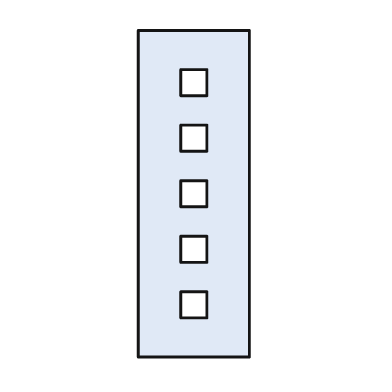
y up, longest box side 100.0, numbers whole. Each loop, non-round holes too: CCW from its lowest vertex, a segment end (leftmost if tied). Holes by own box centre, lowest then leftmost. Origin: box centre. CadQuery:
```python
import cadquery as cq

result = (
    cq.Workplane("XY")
    .moveTo(-17.0, -50.0)
    .lineTo(17.0, -50.0)
    .lineTo(17.0, 50.0)
    .lineTo(-17.0, 50.0)
    .close()
    .moveTo(-4.0, -38.0)
    .lineTo(4.0, -38.0)
    .lineTo(4.0, -30.0)
    .lineTo(-4.0, -30.0)
    .close()
    .moveTo(-4.0, -21.0)
    .lineTo(4.0, -21.0)
    .lineTo(4.0, -13.0)
    .lineTo(-4.0, -13.0)
    .close()
    .moveTo(-4.0, -4.0)
    .lineTo(4.0, -4.0)
    .lineTo(4.0, 4.0)
    .lineTo(-4.0, 4.0)
    .close()
    .moveTo(-4.0, 13.0)
    .lineTo(4.0, 13.0)
    .lineTo(4.0, 21.0)
    .lineTo(-4.0, 21.0)
    .close()
    .moveTo(-4.0, 30.0)
    .lineTo(4.0, 30.0)
    .lineTo(4.0, 38.0)
    .lineTo(-4.0, 38.0)
    .close()
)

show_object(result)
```